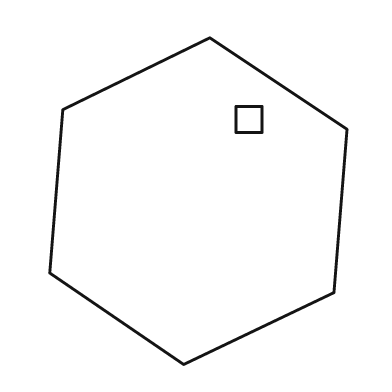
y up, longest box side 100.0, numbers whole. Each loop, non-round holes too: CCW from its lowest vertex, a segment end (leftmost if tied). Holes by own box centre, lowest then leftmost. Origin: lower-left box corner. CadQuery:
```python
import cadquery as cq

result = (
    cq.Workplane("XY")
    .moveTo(41.0, 0.0)
    .lineTo(87.0, 22.0)
    .lineTo(91.0, 72.0)
    .lineTo(49.0, 100.0)
    .lineTo(4.0, 78.0)
    .lineTo(0.0, 28.0)
    .close()
    .moveTo(57.0, 71.0)
    .lineTo(65.0, 71.0)
    .lineTo(65.0, 79.0)
    .lineTo(57.0, 79.0)
    .close()
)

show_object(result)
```